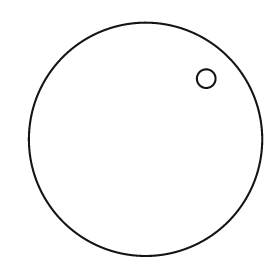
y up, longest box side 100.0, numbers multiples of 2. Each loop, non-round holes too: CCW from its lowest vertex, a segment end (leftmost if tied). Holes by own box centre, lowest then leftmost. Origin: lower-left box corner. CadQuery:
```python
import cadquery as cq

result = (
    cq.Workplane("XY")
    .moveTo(50.0, 50.0)
    .circle(50.0)
    .moveTo(76.0, 76.0)
    .circle(4.0)
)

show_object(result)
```